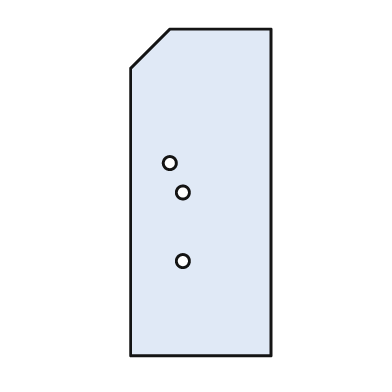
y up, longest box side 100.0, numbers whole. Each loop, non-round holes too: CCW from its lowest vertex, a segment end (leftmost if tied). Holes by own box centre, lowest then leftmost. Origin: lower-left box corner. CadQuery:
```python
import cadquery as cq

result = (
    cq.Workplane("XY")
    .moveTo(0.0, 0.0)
    .lineTo(43.0, 0.0)
    .lineTo(43.0, 100.0)
    .lineTo(12.0, 100.0)
    .lineTo(0.0, 88.0)
    .close()
    .moveTo(16.0, 29.0)
    .circle(2.0)
    .moveTo(16.0, 50.0)
    .circle(2.0)
    .moveTo(12.0, 59.0)
    .circle(2.0)
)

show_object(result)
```